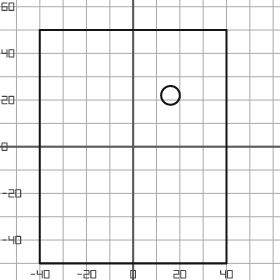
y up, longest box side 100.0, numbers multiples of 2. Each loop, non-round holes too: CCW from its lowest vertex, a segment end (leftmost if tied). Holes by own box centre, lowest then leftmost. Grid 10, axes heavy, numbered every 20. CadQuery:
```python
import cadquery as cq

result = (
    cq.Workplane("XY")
    .moveTo(-40.0, -50.0)
    .lineTo(40.0, -50.0)
    .lineTo(40.0, 50.0)
    .lineTo(-40.0, 50.0)
    .close()
    .moveTo(16.0, 22.0)
    .circle(4.0)
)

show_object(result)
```